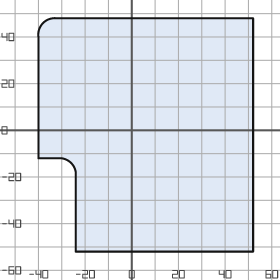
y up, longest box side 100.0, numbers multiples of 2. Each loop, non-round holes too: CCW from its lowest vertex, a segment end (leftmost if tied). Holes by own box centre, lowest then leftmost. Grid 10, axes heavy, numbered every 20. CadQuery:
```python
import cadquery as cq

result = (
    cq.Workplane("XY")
    .moveTo(-24.0, -52.0)
    .lineTo(52.0, -52.0)
    .lineTo(52.0, 48.0)
    .lineTo(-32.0, 48.0)
    .threePointArc((-38.0, 46.0), (-40.0, 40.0))
    .lineTo(-40.0, -12.0)
    .lineTo(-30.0, -12.0)
    .threePointArc((-26.0, -14.0), (-24.0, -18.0))
    .close()
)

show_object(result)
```